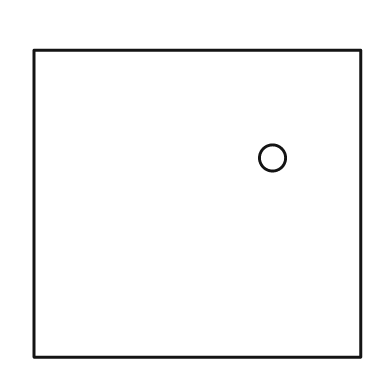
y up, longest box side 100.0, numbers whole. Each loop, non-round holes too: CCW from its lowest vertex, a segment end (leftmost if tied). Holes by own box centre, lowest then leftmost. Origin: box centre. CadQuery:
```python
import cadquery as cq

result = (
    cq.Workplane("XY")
    .moveTo(-50.0, -47.0)
    .lineTo(50.0, -47.0)
    .lineTo(50.0, 47.0)
    .lineTo(-50.0, 47.0)
    .close()
    .moveTo(23.0, 14.0)
    .circle(4.0)
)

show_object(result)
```